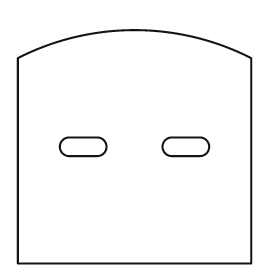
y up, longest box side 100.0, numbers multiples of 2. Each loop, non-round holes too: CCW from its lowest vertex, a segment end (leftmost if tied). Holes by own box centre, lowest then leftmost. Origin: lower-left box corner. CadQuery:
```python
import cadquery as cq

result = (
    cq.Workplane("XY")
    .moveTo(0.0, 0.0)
    .lineTo(100.0, 0.0)
    .lineTo(100.0, 88.0)
    .threePointArc((50.0, 100.0), (0.0, 88.0))
    .close()
    .moveTo(22.0, 46.0)
    .lineTo(34.0, 46.0)
    .threePointArc((38.0, 50.0), (34.0, 54.0))
    .lineTo(22.0, 54.0)
    .threePointArc((18.0, 50.0), (22.0, 46.0))
    .close()
    .moveTo(66.0, 46.0)
    .lineTo(78.0, 46.0)
    .threePointArc((82.0, 50.0), (78.0, 54.0))
    .lineTo(66.0, 54.0)
    .threePointArc((62.0, 50.0), (66.0, 46.0))
    .close()
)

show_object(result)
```